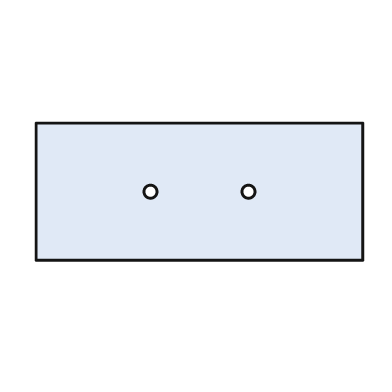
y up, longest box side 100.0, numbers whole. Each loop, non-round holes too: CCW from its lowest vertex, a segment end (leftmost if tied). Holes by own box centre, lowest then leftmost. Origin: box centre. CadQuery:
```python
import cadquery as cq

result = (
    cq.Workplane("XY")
    .moveTo(-50.0, -21.0)
    .lineTo(50.0, -21.0)
    .lineTo(50.0, 21.0)
    .lineTo(-50.0, 21.0)
    .close()
    .moveTo(-15.0, 0.0)
    .circle(2.0)
    .moveTo(15.0, 0.0)
    .circle(2.0)
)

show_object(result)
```